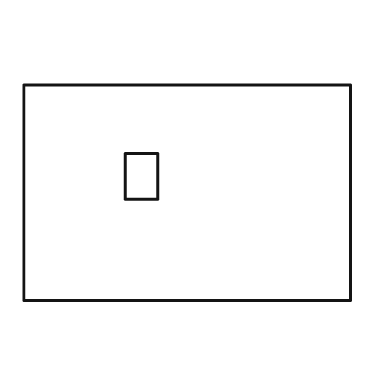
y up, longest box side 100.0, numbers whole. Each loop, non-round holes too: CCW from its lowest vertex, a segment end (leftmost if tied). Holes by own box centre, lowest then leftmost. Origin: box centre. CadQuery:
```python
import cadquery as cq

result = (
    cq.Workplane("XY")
    .moveTo(-50.0, -33.0)
    .lineTo(50.0, -33.0)
    .lineTo(50.0, 33.0)
    .lineTo(-50.0, 33.0)
    .close()
    .moveTo(-19.0, -2.0)
    .lineTo(-9.0, -2.0)
    .lineTo(-9.0, 12.0)
    .lineTo(-19.0, 12.0)
    .close()
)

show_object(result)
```